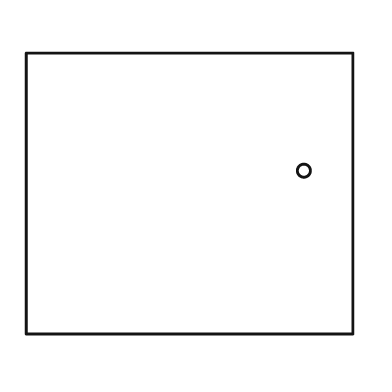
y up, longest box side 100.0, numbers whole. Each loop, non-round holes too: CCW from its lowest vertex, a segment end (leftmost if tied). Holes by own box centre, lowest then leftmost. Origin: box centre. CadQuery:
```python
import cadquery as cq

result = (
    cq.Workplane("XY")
    .moveTo(-50.0, -43.0)
    .lineTo(50.0, -43.0)
    .lineTo(50.0, 43.0)
    .lineTo(-50.0, 43.0)
    .close()
    .moveTo(35.0, 7.0)
    .circle(2.0)
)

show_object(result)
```